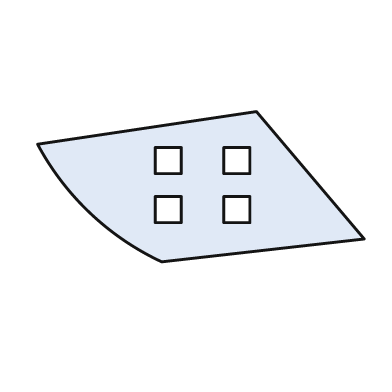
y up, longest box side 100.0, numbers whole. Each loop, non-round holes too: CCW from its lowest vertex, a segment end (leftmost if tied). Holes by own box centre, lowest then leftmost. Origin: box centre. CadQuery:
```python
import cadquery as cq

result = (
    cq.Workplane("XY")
    .moveTo(-12.0, -23.0)
    .lineTo(50.0, -16.0)
    .lineTo(17.0, 23.0)
    .lineTo(-50.0, 13.0)
    .threePointArc((-34.0, -8.0), (-12.0, -23.0))
    .close()
    .moveTo(-14.0, -11.0)
    .lineTo(-6.0, -11.0)
    .lineTo(-6.0, -3.0)
    .lineTo(-14.0, -3.0)
    .close()
    .moveTo(7.0, -11.0)
    .lineTo(15.0, -11.0)
    .lineTo(15.0, -3.0)
    .lineTo(7.0, -3.0)
    .close()
    .moveTo(-14.0, 4.0)
    .lineTo(-6.0, 4.0)
    .lineTo(-6.0, 12.0)
    .lineTo(-14.0, 12.0)
    .close()
    .moveTo(7.0, 4.0)
    .lineTo(15.0, 4.0)
    .lineTo(15.0, 12.0)
    .lineTo(7.0, 12.0)
    .close()
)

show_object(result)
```